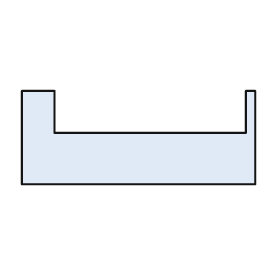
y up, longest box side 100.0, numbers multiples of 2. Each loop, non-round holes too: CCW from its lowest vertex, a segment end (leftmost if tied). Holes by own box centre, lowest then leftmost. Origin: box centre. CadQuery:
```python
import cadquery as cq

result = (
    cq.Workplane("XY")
    .moveTo(-50.0, -20.0)
    .lineTo(50.0, -20.0)
    .lineTo(50.0, 20.0)
    .lineTo(46.0, 20.0)
    .lineTo(46.0, 2.0)
    .lineTo(-36.0, 2.0)
    .lineTo(-36.0, 20.0)
    .lineTo(-50.0, 20.0)
    .close()
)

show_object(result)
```